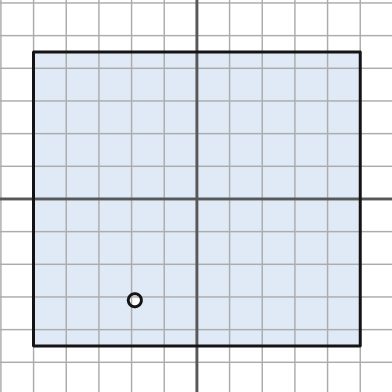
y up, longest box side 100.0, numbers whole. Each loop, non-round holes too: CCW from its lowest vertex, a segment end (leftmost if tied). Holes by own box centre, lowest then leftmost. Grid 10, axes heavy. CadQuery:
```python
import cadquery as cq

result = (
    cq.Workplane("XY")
    .moveTo(-50.0, -45.0)
    .lineTo(50.0, -45.0)
    .lineTo(50.0, 45.0)
    .lineTo(-50.0, 45.0)
    .close()
    .moveTo(-19.0, -31.0)
    .circle(2.0)
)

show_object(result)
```